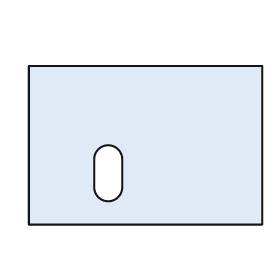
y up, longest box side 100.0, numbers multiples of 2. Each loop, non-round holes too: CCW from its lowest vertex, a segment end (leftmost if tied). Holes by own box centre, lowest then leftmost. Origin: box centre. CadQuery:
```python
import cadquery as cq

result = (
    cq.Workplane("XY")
    .moveTo(-50.0, -34.0)
    .lineTo(50.0, -34.0)
    .lineTo(50.0, 34.0)
    .lineTo(-50.0, 34.0)
    .close()
    .moveTo(-22.0, -18.0)
    .threePointArc((-16.0, -24.0), (-10.0, -18.0))
    .lineTo(-10.0, -6.0)
    .threePointArc((-16.0, 0.0), (-22.0, -6.0))
    .close()
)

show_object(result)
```